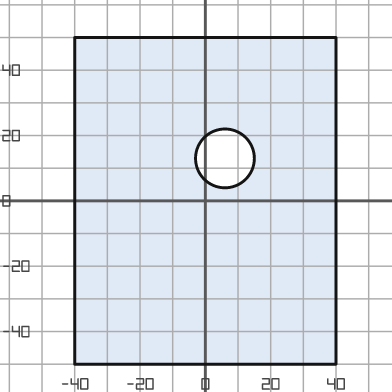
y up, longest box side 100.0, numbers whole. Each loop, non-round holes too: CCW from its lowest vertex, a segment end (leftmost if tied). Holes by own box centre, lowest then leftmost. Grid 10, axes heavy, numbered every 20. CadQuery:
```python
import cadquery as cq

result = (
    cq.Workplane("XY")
    .moveTo(-40.0, -50.0)
    .lineTo(40.0, -50.0)
    .lineTo(40.0, 50.0)
    .lineTo(-40.0, 50.0)
    .close()
    .moveTo(6.0, 13.0)
    .circle(9.0)
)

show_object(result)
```